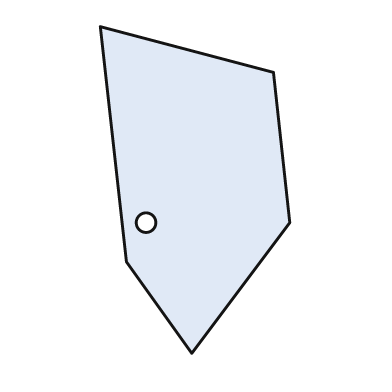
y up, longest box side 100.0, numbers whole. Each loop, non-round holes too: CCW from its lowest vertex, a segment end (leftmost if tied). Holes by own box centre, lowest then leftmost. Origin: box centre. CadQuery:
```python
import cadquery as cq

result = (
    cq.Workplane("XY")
    .moveTo(-1.0, -50.0)
    .lineTo(29.0, -10.0)
    .lineTo(24.0, 36.0)
    .lineTo(-29.0, 50.0)
    .lineTo(-21.0, -22.0)
    .close()
    .moveTo(-15.0, -10.0)
    .circle(3.0)
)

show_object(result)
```